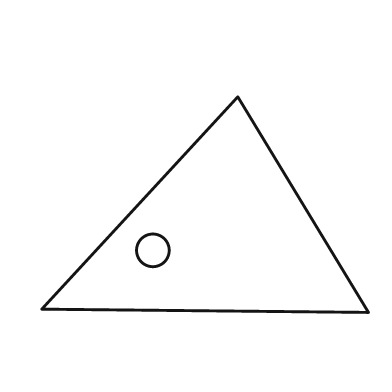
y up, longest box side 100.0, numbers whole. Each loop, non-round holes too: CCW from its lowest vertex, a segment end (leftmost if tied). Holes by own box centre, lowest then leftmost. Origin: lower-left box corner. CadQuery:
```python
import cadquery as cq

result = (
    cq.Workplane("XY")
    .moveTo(100.0, 0.0)
    .lineTo(60.0, 66.0)
    .lineTo(0.0, 1.0)
    .close()
    .moveTo(34.0, 19.0)
    .circle(5.0)
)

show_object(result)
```